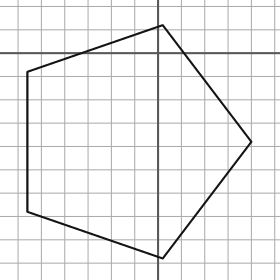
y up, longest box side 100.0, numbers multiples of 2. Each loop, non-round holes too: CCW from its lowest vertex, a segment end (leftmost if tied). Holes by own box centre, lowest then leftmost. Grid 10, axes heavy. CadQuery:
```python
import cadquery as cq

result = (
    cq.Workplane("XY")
    .moveTo(2.0, -88.0)
    .lineTo(40.0, -38.0)
    .lineTo(2.0, 12.0)
    .lineTo(-56.0, -8.0)
    .lineTo(-56.0, -68.0)
    .close()
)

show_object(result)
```